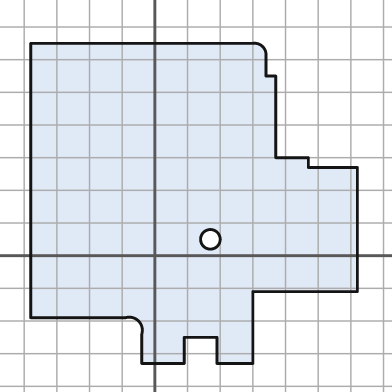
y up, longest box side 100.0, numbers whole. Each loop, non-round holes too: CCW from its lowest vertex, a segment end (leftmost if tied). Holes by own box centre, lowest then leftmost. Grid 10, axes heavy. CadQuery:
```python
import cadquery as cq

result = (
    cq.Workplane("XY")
    .moveTo(-4.0, -33.0)
    .lineTo(9.0, -33.0)
    .lineTo(9.0, -25.0)
    .lineTo(19.0, -25.0)
    .lineTo(19.0, -33.0)
    .lineTo(30.0, -33.0)
    .lineTo(30.0, -11.0)
    .lineTo(62.0, -11.0)
    .lineTo(62.0, 27.0)
    .lineTo(47.0, 27.0)
    .lineTo(47.0, 30.0)
    .lineTo(37.0, 30.0)
    .lineTo(37.0, 55.0)
    .lineTo(34.0, 55.0)
    .lineTo(34.0, 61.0)
    .threePointArc((33.0, 64.0), (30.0, 65.0))
    .lineTo(-38.0, 65.0)
    .lineTo(-38.0, -19.0)
    .lineTo(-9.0, -19.0)
    .threePointArc((-5.0, -20.0), (-4.0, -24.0))
    .close()
    .moveTo(17.0, 5.0)
    .circle(3.0)
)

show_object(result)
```